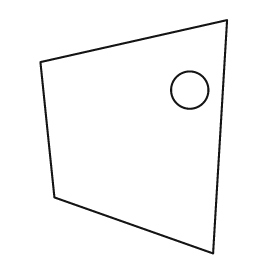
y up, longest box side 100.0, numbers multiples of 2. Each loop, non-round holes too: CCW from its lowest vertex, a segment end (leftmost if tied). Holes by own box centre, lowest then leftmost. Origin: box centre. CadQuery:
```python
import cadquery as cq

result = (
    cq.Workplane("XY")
    .moveTo(34.0, -50.0)
    .lineTo(40.0, 50.0)
    .lineTo(-40.0, 32.0)
    .lineTo(-34.0, -26.0)
    .close()
    .moveTo(24.0, 20.0)
    .circle(8.0)
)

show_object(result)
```